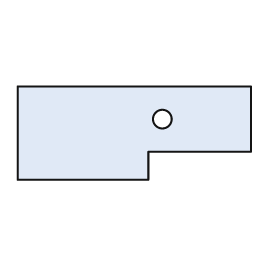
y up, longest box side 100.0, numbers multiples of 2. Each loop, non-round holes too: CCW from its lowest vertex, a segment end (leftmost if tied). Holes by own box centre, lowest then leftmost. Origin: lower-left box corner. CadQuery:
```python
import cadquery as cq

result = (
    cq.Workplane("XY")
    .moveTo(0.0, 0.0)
    .lineTo(56.0, 0.0)
    .lineTo(56.0, 12.0)
    .lineTo(100.0, 12.0)
    .lineTo(100.0, 40.0)
    .lineTo(0.0, 40.0)
    .close()
    .moveTo(62.0, 26.0)
    .circle(4.0)
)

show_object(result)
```